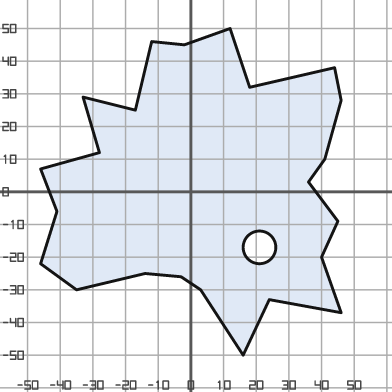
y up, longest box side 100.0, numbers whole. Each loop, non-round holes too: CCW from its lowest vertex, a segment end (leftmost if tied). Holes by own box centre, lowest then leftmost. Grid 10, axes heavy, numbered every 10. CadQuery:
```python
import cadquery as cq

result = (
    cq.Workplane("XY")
    .moveTo(16.0, -50.0)
    .lineTo(24.0, -33.0)
    .lineTo(46.0, -37.0)
    .lineTo(40.0, -20.0)
    .lineTo(45.0, -9.0)
    .lineTo(36.0, 3.0)
    .lineTo(41.0, 10.0)
    .lineTo(46.0, 28.0)
    .lineTo(44.0, 38.0)
    .lineTo(18.0, 32.0)
    .lineTo(12.0, 50.0)
    .lineTo(-2.0, 45.0)
    .lineTo(-12.0, 46.0)
    .lineTo(-17.0, 25.0)
    .lineTo(-33.0, 29.0)
    .lineTo(-28.0, 12.0)
    .lineTo(-46.0, 7.0)
    .lineTo(-41.0, -6.0)
    .lineTo(-46.0, -22.0)
    .lineTo(-35.0, -30.0)
    .lineTo(-14.0, -25.0)
    .lineTo(-3.0, -26.0)
    .lineTo(3.0, -30.0)
    .close()
    .moveTo(21.0, -17.0)
    .circle(5.0)
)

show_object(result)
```